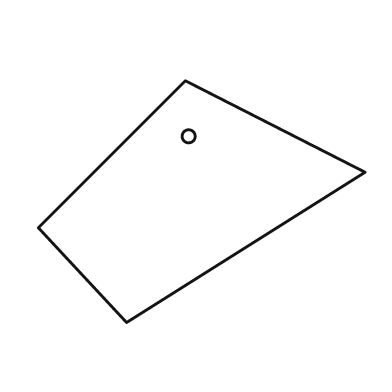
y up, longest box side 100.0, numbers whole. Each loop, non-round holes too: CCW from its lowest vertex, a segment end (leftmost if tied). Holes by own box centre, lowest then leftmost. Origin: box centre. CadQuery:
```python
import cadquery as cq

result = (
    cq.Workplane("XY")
    .moveTo(-23.0, -37.0)
    .lineTo(50.0, 9.0)
    .lineTo(-5.0, 37.0)
    .lineTo(-50.0, -8.0)
    .close()
    .moveTo(-4.0, 20.0)
    .circle(2.0)
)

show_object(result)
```